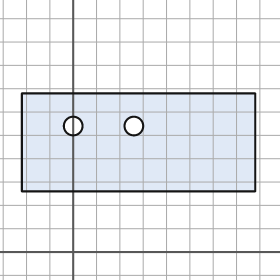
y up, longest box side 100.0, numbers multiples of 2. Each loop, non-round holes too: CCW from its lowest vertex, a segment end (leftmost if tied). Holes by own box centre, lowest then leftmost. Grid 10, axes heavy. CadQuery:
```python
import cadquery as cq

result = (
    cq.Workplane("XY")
    .moveTo(-22.0, 26.0)
    .lineTo(78.0, 26.0)
    .lineTo(78.0, 68.0)
    .lineTo(-22.0, 68.0)
    .close()
    .moveTo(0.0, 54.0)
    .circle(4.0)
    .moveTo(26.0, 54.0)
    .circle(4.0)
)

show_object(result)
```